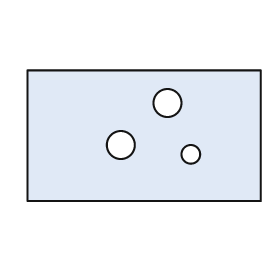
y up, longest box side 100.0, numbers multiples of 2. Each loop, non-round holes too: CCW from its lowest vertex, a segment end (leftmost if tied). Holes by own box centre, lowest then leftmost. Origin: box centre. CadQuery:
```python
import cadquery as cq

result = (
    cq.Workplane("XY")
    .moveTo(-50.0, -28.0)
    .lineTo(50.0, -28.0)
    .lineTo(50.0, 28.0)
    .lineTo(-50.0, 28.0)
    .close()
    .moveTo(20.0, -8.0)
    .circle(4.0)
    .moveTo(-10.0, -4.0)
    .circle(6.0)
    .moveTo(10.0, 14.0)
    .circle(6.0)
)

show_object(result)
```